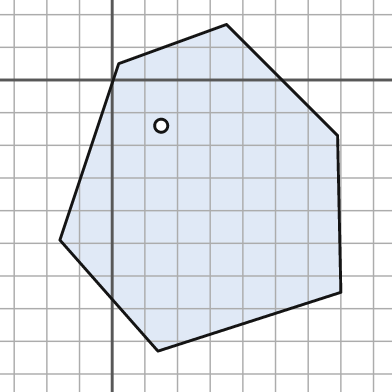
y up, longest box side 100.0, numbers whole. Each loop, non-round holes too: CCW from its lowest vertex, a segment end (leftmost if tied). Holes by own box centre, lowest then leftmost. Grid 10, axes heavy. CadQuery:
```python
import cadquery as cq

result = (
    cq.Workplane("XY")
    .moveTo(14.0, -83.0)
    .lineTo(70.0, -65.0)
    .lineTo(69.0, -17.0)
    .lineTo(35.0, 17.0)
    .lineTo(2.0, 5.0)
    .lineTo(-16.0, -49.0)
    .close()
    .moveTo(15.0, -14.0)
    .circle(2.0)
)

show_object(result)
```